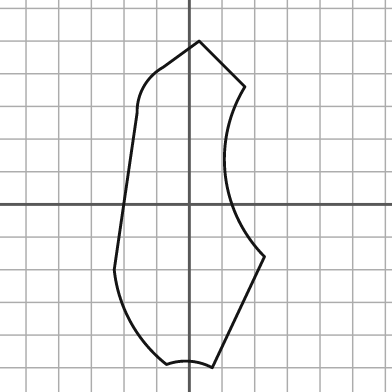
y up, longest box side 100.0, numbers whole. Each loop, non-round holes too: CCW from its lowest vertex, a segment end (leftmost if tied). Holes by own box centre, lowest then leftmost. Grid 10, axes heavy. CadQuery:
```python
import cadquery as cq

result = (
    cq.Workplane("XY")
    .moveTo(7.0, -50.0)
    .lineTo(23.0, -16.0)
    .threePointArc((11.0, 9.0), (17.0, 36.0))
    .lineTo(3.0, 50.0)
    .lineTo(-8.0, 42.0)
    .threePointArc((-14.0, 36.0), (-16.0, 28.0))
    .lineTo(-23.0, -20.0)
    .threePointArc((-18.0, -36.0), (-7.0, -49.0))
    .threePointArc((0.0, -48.0), (7.0, -50.0))
    .close()
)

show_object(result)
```